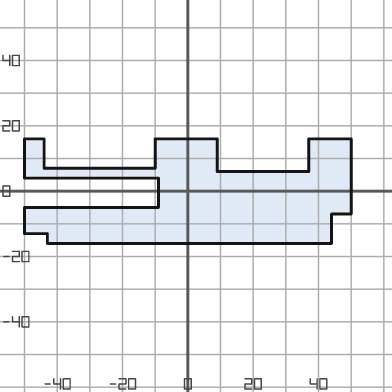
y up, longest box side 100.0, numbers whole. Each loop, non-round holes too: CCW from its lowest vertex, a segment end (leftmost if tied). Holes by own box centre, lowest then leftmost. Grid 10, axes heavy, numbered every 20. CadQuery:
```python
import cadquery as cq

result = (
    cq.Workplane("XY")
    .moveTo(-43.0, -16.0)
    .lineTo(44.0, -16.0)
    .lineTo(44.0, -7.0)
    .lineTo(50.0, -7.0)
    .lineTo(50.0, 16.0)
    .lineTo(37.0, 16.0)
    .lineTo(37.0, 6.0)
    .lineTo(9.0, 6.0)
    .lineTo(9.0, 16.0)
    .lineTo(-10.0, 16.0)
    .lineTo(-10.0, 7.0)
    .lineTo(-44.0, 7.0)
    .lineTo(-44.0, 16.0)
    .lineTo(-50.0, 16.0)
    .lineTo(-50.0, 4.0)
    .lineTo(-9.0, 4.0)
    .lineTo(-9.0, -5.0)
    .lineTo(-50.0, -5.0)
    .lineTo(-50.0, -13.0)
    .lineTo(-43.0, -13.0)
    .close()
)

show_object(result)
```